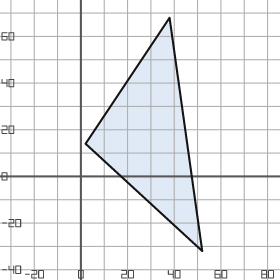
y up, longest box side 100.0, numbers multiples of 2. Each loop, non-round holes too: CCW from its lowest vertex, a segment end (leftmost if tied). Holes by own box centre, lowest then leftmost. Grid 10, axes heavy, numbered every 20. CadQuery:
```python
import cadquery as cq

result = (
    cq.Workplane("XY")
    .moveTo(52.0, -32.0)
    .lineTo(38.0, 68.0)
    .lineTo(2.0, 14.0)
    .close()
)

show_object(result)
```